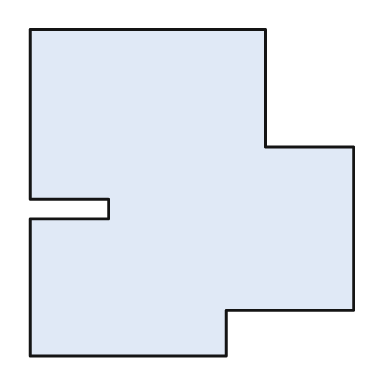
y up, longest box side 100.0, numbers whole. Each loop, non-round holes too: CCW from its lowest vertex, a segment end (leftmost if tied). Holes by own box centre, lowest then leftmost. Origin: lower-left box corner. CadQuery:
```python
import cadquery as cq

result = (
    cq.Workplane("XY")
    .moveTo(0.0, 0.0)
    .lineTo(60.0, 0.0)
    .lineTo(60.0, 14.0)
    .lineTo(99.0, 14.0)
    .lineTo(99.0, 64.0)
    .lineTo(72.0, 64.0)
    .lineTo(72.0, 100.0)
    .lineTo(0.0, 100.0)
    .lineTo(0.0, 48.0)
    .lineTo(24.0, 48.0)
    .lineTo(24.0, 42.0)
    .lineTo(0.0, 42.0)
    .close()
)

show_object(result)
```